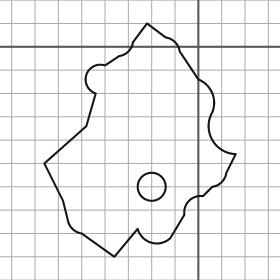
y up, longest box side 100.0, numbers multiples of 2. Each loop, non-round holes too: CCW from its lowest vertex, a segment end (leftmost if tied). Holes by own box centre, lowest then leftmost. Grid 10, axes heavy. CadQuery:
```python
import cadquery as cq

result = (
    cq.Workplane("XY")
    .moveTo(-36.0, -90.0)
    .lineTo(-26.0, -78.0)
    .threePointArc((-20.0, -84.0), (-12.0, -82.0))
    .lineTo(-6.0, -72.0)
    .threePointArc((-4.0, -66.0), (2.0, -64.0))
    .lineTo(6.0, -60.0)
    .threePointArc((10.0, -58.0), (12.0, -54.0))
    .lineTo(16.0, -46.0)
    .threePointArc((6.0, -40.0), (6.0, -28.0))
    .threePointArc((6.0, -20.0), (0.0, -14.0))
    .lineTo(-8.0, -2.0)
    .threePointArc((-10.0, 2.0), (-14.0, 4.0))
    .lineTo(-22.0, 10.0)
    .lineTo(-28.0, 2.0)
    .threePointArc((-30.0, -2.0), (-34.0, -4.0))
    .lineTo(-40.0, -8.0)
    .threePointArc((-48.0, -12.0), (-44.0, -20.0))
    .lineTo(-48.0, -34.0)
    .lineTo(-66.0, -50.0)
    .lineTo(-58.0, -66.0)
    .lineTo(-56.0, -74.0)
    .threePointArc((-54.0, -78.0), (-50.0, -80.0))
    .close()
    .moveTo(-20.0, -60.0)
    .circle(6.0)
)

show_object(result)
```